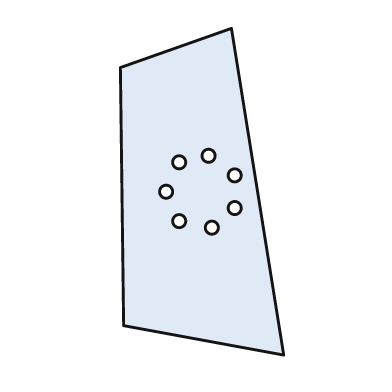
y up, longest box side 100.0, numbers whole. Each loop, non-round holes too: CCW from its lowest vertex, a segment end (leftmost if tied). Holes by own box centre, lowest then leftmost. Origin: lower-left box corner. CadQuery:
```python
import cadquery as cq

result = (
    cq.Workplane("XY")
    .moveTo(50.0, 0.0)
    .lineTo(34.0, 100.0)
    .lineTo(0.0, 88.0)
    .lineTo(1.0, 9.0)
    .close()
    .moveTo(28.0, 39.0)
    .circle(2.0)
    .moveTo(18.0, 41.0)
    .circle(2.0)
    .moveTo(35.0, 45.0)
    .circle(2.0)
    .moveTo(14.0, 50.0)
    .circle(2.0)
    .moveTo(35.0, 55.0)
    .circle(2.0)
    .moveTo(18.0, 59.0)
    .circle(2.0)
    .moveTo(27.0, 61.0)
    .circle(2.0)
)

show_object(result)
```